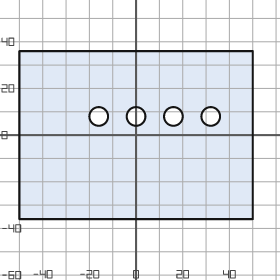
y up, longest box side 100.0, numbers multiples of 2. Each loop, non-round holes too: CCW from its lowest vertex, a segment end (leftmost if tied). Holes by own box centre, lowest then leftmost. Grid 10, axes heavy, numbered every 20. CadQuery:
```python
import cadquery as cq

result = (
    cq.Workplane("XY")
    .moveTo(-50.0, -36.0)
    .lineTo(50.0, -36.0)
    .lineTo(50.0, 36.0)
    .lineTo(-50.0, 36.0)
    .close()
    .moveTo(-16.0, 8.0)
    .circle(4.0)
    .moveTo(0.0, 8.0)
    .circle(4.0)
    .moveTo(16.0, 8.0)
    .circle(4.0)
    .moveTo(32.0, 8.0)
    .circle(4.0)
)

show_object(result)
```